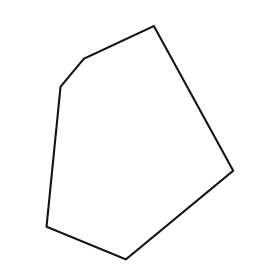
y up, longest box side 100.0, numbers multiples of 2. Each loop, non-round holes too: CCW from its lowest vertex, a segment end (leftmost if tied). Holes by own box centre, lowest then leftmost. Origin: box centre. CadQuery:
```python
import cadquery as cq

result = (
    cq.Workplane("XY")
    .moveTo(-6.0, -50.0)
    .lineTo(40.0, -12.0)
    .lineTo(6.0, 50.0)
    .lineTo(-24.0, 36.0)
    .lineTo(-34.0, 24.0)
    .lineTo(-40.0, -36.0)
    .close()
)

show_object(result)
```